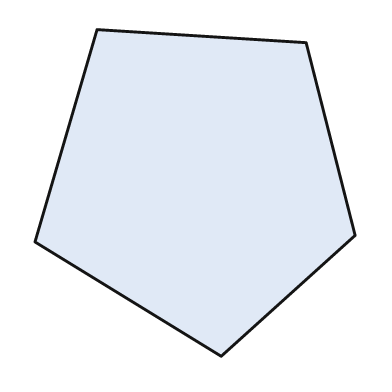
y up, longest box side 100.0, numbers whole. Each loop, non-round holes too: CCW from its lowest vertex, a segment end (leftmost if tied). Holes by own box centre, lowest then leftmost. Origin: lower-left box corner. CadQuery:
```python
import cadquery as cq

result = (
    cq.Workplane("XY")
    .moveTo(57.0, 0.0)
    .lineTo(98.0, 37.0)
    .lineTo(83.0, 96.0)
    .lineTo(19.0, 100.0)
    .lineTo(0.0, 35.0)
    .close()
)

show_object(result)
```